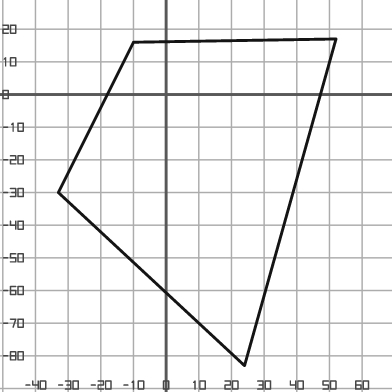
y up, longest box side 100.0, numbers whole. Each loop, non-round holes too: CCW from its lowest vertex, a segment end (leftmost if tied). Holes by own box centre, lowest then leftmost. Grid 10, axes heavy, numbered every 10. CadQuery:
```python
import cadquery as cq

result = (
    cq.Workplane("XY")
    .moveTo(24.0, -83.0)
    .lineTo(52.0, 17.0)
    .lineTo(-10.0, 16.0)
    .lineTo(-33.0, -30.0)
    .close()
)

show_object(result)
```